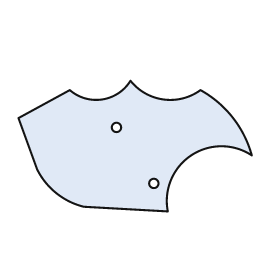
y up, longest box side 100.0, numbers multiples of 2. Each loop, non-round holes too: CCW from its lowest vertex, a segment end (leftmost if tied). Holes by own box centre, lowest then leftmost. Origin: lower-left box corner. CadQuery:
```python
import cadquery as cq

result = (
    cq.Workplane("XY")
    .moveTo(64.0, 0.0)
    .threePointArc((74.0, 24.0), (100.0, 24.0))
    .threePointArc((92.0, 40.0), (78.0, 52.0))
    .threePointArc((62.0, 48.0), (48.0, 56.0))
    .threePointArc((36.0, 48.0), (22.0, 52.0))
    .lineTo(0.0, 40.0)
    .lineTo(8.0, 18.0)
    .threePointArc((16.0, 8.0), (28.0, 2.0))
    .close()
    .moveTo(58.0, 12.0)
    .circle(2.0)
    .moveTo(42.0, 36.0)
    .circle(2.0)
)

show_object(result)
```